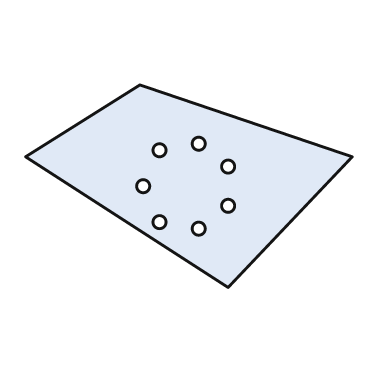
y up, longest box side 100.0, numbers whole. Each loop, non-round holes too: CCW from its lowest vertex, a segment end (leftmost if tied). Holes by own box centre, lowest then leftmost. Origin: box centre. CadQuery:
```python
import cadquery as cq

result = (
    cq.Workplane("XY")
    .moveTo(12.0, -31.0)
    .lineTo(50.0, 9.0)
    .lineTo(-15.0, 31.0)
    .lineTo(-50.0, 9.0)
    .close()
    .moveTo(3.0, -13.0)
    .circle(2.0)
    .moveTo(-9.0, -11.0)
    .circle(2.0)
    .moveTo(12.0, -6.0)
    .circle(2.0)
    .moveTo(-14.0, 0.0)
    .circle(2.0)
    .moveTo(12.0, 6.0)
    .circle(2.0)
    .moveTo(-9.0, 11.0)
    .circle(2.0)
    .moveTo(3.0, 13.0)
    .circle(2.0)
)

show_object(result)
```